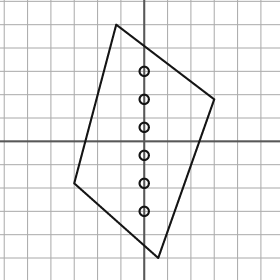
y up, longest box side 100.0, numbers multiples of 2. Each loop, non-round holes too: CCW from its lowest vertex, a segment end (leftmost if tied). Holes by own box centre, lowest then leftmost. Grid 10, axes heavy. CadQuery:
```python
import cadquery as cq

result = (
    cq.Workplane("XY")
    .moveTo(6.0, -50.0)
    .lineTo(30.0, 18.0)
    .lineTo(-12.0, 50.0)
    .lineTo(-30.0, -18.0)
    .close()
    .moveTo(0.0, -30.0)
    .circle(2.0)
    .moveTo(0.0, -18.0)
    .circle(2.0)
    .moveTo(0.0, -6.0)
    .circle(2.0)
    .moveTo(0.0, 6.0)
    .circle(2.0)
    .moveTo(0.0, 18.0)
    .circle(2.0)
    .moveTo(0.0, 30.0)
    .circle(2.0)
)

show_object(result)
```